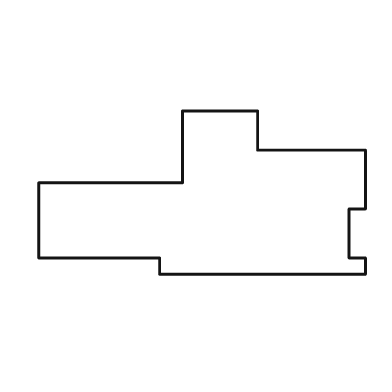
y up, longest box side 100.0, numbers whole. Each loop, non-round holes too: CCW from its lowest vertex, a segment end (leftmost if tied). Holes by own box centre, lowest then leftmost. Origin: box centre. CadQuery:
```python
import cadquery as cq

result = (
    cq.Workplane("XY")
    .moveTo(-13.0, -25.0)
    .lineTo(50.0, -25.0)
    .lineTo(50.0, -20.0)
    .lineTo(45.0, -20.0)
    .lineTo(45.0, -5.0)
    .lineTo(50.0, -5.0)
    .lineTo(50.0, 13.0)
    .lineTo(17.0, 13.0)
    .lineTo(17.0, 25.0)
    .lineTo(-6.0, 25.0)
    .lineTo(-6.0, 3.0)
    .lineTo(-50.0, 3.0)
    .lineTo(-50.0, -20.0)
    .lineTo(-13.0, -20.0)
    .close()
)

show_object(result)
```